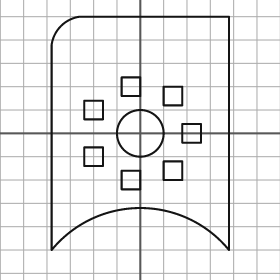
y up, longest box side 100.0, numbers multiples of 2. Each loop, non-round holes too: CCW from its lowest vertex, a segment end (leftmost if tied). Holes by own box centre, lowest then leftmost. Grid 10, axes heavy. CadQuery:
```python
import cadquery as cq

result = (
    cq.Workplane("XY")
    .moveTo(-38.0, -50.0)
    .threePointArc((0.0, -32.0), (38.0, -50.0))
    .lineTo(38.0, 50.0)
    .lineTo(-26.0, 50.0)
    .threePointArc((-34.0, 46.0), (-38.0, 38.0))
    .close()
    .moveTo(-8.0, -24.0)
    .lineTo(0.0, -24.0)
    .lineTo(0.0, -16.0)
    .lineTo(-8.0, -16.0)
    .close()
    .moveTo(10.0, -20.0)
    .lineTo(18.0, -20.0)
    .lineTo(18.0, -12.0)
    .lineTo(10.0, -12.0)
    .close()
    .moveTo(-24.0, -14.0)
    .lineTo(-16.0, -14.0)
    .lineTo(-16.0, -6.0)
    .lineTo(-24.0, -6.0)
    .close()
    .moveTo(0.0, 0.0)
    .circle(10.0)
    .moveTo(18.0, -4.0)
    .lineTo(26.0, -4.0)
    .lineTo(26.0, 4.0)
    .lineTo(18.0, 4.0)
    .close()
    .moveTo(-24.0, 6.0)
    .lineTo(-16.0, 6.0)
    .lineTo(-16.0, 14.0)
    .lineTo(-24.0, 14.0)
    .close()
    .moveTo(10.0, 12.0)
    .lineTo(18.0, 12.0)
    .lineTo(18.0, 20.0)
    .lineTo(10.0, 20.0)
    .close()
    .moveTo(-8.0, 16.0)
    .lineTo(0.0, 16.0)
    .lineTo(0.0, 24.0)
    .lineTo(-8.0, 24.0)
    .close()
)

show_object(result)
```